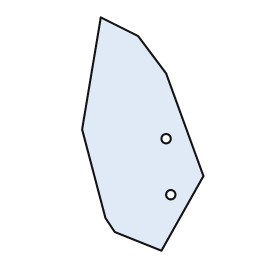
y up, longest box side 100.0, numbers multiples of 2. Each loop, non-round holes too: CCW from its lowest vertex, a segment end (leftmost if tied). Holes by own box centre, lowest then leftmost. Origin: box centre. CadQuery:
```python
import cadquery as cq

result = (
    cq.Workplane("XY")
    .moveTo(8.0, -50.0)
    .lineTo(26.0, -18.0)
    .lineTo(10.0, 26.0)
    .lineTo(-2.0, 42.0)
    .lineTo(-18.0, 50.0)
    .lineTo(-26.0, 2.0)
    .lineTo(-16.0, -36.0)
    .lineTo(-12.0, -42.0)
    .close()
    .moveTo(12.0, -26.0)
    .circle(2.0)
    .moveTo(10.0, -2.0)
    .circle(2.0)
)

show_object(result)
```